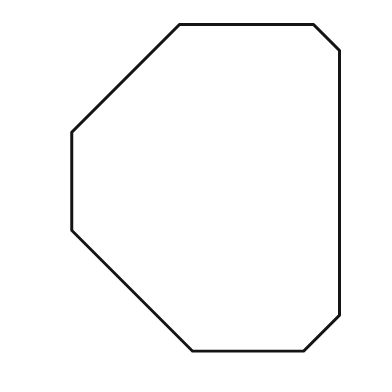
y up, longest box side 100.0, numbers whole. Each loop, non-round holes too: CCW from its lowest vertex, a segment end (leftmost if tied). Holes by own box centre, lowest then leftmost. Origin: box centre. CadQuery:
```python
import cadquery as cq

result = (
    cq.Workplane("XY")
    .moveTo(-4.0, -50.0)
    .lineTo(30.0, -50.0)
    .lineTo(41.0, -39.0)
    .lineTo(41.0, 42.0)
    .lineTo(33.0, 50.0)
    .lineTo(-8.0, 50.0)
    .lineTo(-41.0, 17.0)
    .lineTo(-41.0, -13.0)
    .close()
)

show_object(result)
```